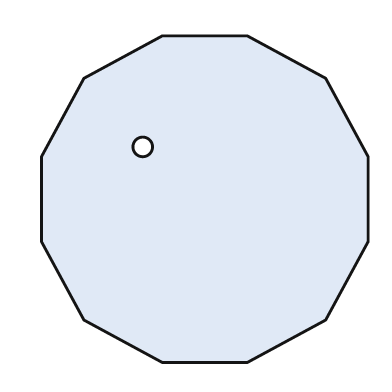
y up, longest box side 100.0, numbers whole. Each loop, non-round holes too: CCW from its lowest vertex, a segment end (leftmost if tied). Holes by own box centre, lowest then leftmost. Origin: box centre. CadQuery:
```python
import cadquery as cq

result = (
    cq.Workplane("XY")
    .moveTo(-13.0, -50.0)
    .lineTo(13.0, -50.0)
    .lineTo(37.0, -37.0)
    .lineTo(50.0, -13.0)
    .lineTo(50.0, 13.0)
    .lineTo(37.0, 37.0)
    .lineTo(13.0, 50.0)
    .lineTo(-13.0, 50.0)
    .lineTo(-37.0, 37.0)
    .lineTo(-50.0, 13.0)
    .lineTo(-50.0, -13.0)
    .lineTo(-37.0, -37.0)
    .close()
    .moveTo(-19.0, 16.0)
    .circle(3.0)
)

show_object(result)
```